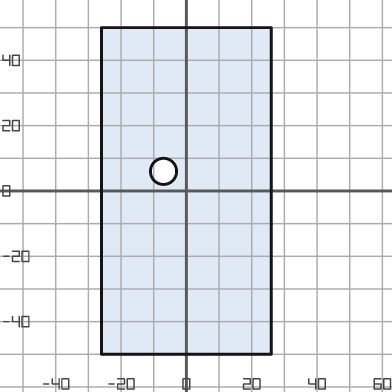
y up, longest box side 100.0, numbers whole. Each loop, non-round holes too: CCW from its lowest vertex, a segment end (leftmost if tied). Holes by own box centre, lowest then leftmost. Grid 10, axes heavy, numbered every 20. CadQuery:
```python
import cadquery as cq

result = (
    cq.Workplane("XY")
    .moveTo(-26.0, -50.0)
    .lineTo(26.0, -50.0)
    .lineTo(26.0, 50.0)
    .lineTo(-26.0, 50.0)
    .close()
    .moveTo(-7.0, 6.0)
    .circle(4.0)
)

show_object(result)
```